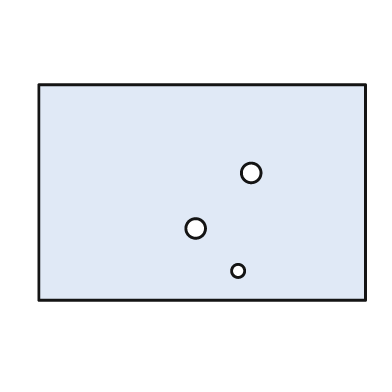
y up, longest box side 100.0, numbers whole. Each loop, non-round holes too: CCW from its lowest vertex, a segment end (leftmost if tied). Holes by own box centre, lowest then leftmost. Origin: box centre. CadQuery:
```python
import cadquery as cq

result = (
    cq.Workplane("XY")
    .moveTo(-50.0, -33.0)
    .lineTo(50.0, -33.0)
    .lineTo(50.0, 33.0)
    .lineTo(-50.0, 33.0)
    .close()
    .moveTo(11.0, -24.0)
    .circle(2.0)
    .moveTo(-2.0, -11.0)
    .circle(3.0)
    .moveTo(15.0, 6.0)
    .circle(3.0)
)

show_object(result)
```